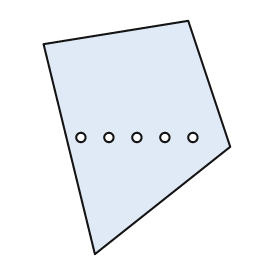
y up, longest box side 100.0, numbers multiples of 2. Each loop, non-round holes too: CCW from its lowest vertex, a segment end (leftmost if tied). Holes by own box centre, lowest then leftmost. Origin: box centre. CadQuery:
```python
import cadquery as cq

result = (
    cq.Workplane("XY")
    .moveTo(-18.0, -50.0)
    .lineTo(40.0, -4.0)
    .lineTo(22.0, 50.0)
    .lineTo(-40.0, 40.0)
    .close()
    .moveTo(-24.0, 0.0)
    .circle(2.0)
    .moveTo(-12.0, 0.0)
    .circle(2.0)
    .moveTo(0.0, 0.0)
    .circle(2.0)
    .moveTo(12.0, 0.0)
    .circle(2.0)
    .moveTo(24.0, 0.0)
    .circle(2.0)
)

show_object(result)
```